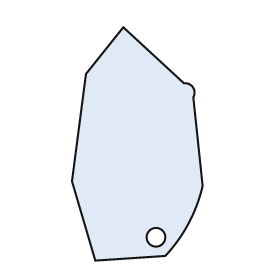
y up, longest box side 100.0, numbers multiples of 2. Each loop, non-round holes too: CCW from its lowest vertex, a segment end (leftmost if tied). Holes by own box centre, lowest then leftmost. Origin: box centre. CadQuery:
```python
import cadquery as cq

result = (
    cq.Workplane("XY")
    .moveTo(-18.0, -50.0)
    .lineTo(12.0, -48.0)
    .threePointArc((22.0, -34.0), (28.0, -18.0))
    .lineTo(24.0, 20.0)
    .threePointArc((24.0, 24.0), (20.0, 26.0))
    .lineTo(-6.0, 50.0)
    .lineTo(-22.0, 30.0)
    .lineTo(-28.0, -16.0)
    .close()
    .moveTo(8.0, -40.0)
    .circle(4.0)
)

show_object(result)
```